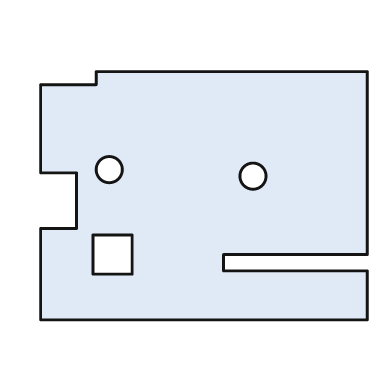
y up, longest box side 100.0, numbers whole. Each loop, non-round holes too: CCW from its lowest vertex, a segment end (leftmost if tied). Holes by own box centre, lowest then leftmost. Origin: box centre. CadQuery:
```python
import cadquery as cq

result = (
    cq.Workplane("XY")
    .moveTo(-50.0, -38.0)
    .lineTo(50.0, -38.0)
    .lineTo(50.0, -23.0)
    .lineTo(6.0, -23.0)
    .lineTo(6.0, -18.0)
    .lineTo(50.0, -18.0)
    .lineTo(50.0, 38.0)
    .lineTo(-33.0, 38.0)
    .lineTo(-33.0, 34.0)
    .lineTo(-50.0, 34.0)
    .lineTo(-50.0, 7.0)
    .lineTo(-39.0, 7.0)
    .lineTo(-39.0, -10.0)
    .lineTo(-50.0, -10.0)
    .close()
    .moveTo(-34.0, -24.0)
    .lineTo(-22.0, -24.0)
    .lineTo(-22.0, -12.0)
    .lineTo(-34.0, -12.0)
    .close()
    .moveTo(15.0, 6.0)
    .circle(4.0)
    .moveTo(-29.0, 8.0)
    .circle(4.0)
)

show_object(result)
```